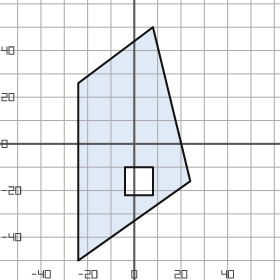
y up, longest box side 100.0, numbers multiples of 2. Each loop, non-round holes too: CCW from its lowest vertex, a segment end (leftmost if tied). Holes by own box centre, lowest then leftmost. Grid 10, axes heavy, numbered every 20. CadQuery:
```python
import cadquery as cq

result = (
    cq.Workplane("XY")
    .moveTo(-24.0, -50.0)
    .lineTo(24.0, -16.0)
    .lineTo(8.0, 50.0)
    .lineTo(-24.0, 26.0)
    .close()
    .moveTo(-4.0, -22.0)
    .lineTo(8.0, -22.0)
    .lineTo(8.0, -10.0)
    .lineTo(-4.0, -10.0)
    .close()
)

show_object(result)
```